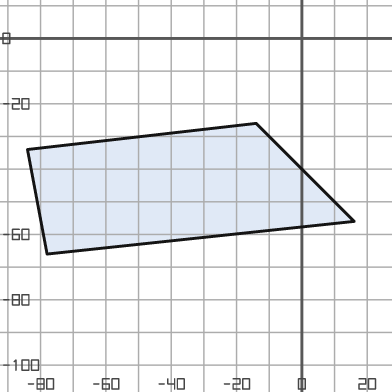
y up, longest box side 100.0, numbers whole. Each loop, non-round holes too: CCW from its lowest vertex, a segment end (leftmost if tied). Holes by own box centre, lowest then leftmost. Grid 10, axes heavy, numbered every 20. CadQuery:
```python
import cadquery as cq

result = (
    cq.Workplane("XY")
    .moveTo(-78.0, -66.0)
    .lineTo(16.0, -56.0)
    .lineTo(-14.0, -26.0)
    .lineTo(-84.0, -34.0)
    .close()
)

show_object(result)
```